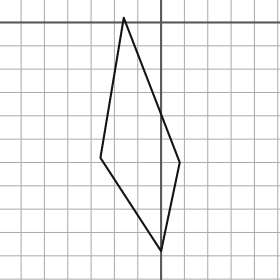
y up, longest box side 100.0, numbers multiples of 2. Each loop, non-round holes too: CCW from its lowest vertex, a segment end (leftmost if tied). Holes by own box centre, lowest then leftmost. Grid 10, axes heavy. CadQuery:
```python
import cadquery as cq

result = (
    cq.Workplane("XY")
    .moveTo(0.0, -98.0)
    .lineTo(8.0, -60.0)
    .lineTo(-16.0, 2.0)
    .lineTo(-26.0, -58.0)
    .close()
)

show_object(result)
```